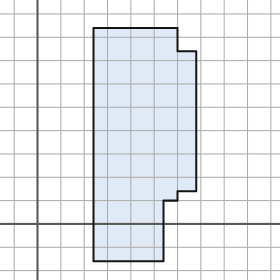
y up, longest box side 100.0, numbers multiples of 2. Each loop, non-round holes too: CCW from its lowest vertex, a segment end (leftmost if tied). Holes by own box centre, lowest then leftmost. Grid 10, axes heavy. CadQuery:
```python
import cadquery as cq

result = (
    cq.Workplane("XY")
    .moveTo(24.0, -16.0)
    .lineTo(54.0, -16.0)
    .lineTo(54.0, 10.0)
    .lineTo(60.0, 10.0)
    .lineTo(60.0, 14.0)
    .lineTo(68.0, 14.0)
    .lineTo(68.0, 74.0)
    .lineTo(60.0, 74.0)
    .lineTo(60.0, 84.0)
    .lineTo(24.0, 84.0)
    .close()
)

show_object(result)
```